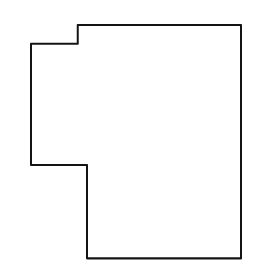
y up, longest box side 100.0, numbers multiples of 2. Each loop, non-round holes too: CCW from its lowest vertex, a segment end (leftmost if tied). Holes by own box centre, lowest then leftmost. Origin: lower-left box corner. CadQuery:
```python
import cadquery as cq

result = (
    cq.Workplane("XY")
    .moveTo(24.0, 0.0)
    .lineTo(90.0, 0.0)
    .lineTo(90.0, 100.0)
    .lineTo(20.0, 100.0)
    .lineTo(20.0, 92.0)
    .lineTo(0.0, 92.0)
    .lineTo(0.0, 40.0)
    .lineTo(24.0, 40.0)
    .close()
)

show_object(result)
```